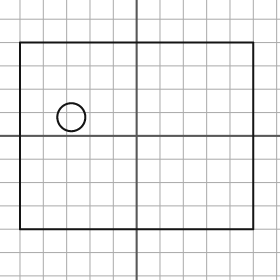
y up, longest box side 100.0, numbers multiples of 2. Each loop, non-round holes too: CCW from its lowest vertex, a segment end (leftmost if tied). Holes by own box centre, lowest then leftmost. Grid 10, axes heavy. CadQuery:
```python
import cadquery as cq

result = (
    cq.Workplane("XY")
    .moveTo(-50.0, -40.0)
    .lineTo(50.0, -40.0)
    .lineTo(50.0, 40.0)
    .lineTo(-50.0, 40.0)
    .close()
    .moveTo(-28.0, 8.0)
    .circle(6.0)
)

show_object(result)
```